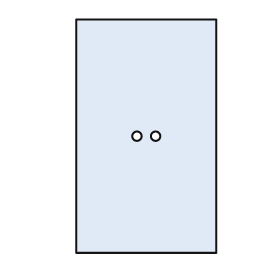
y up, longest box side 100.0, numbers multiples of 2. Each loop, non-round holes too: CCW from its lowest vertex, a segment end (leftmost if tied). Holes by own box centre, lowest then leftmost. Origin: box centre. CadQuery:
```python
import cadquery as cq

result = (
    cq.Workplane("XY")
    .moveTo(-30.0, -50.0)
    .lineTo(30.0, -50.0)
    .lineTo(30.0, 50.0)
    .lineTo(-30.0, 50.0)
    .close()
    .moveTo(-4.0, 0.0)
    .circle(2.0)
    .moveTo(4.0, 0.0)
    .circle(2.0)
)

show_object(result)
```